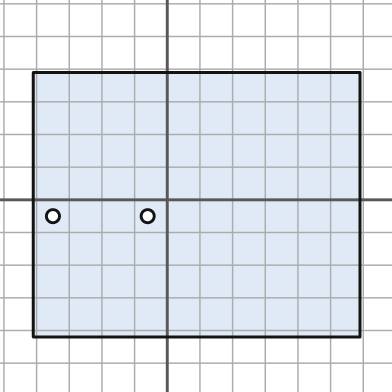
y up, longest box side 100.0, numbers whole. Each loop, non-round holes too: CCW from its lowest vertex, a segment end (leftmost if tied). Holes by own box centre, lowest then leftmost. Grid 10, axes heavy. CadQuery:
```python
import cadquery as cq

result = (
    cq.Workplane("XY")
    .moveTo(-41.0, -42.0)
    .lineTo(59.0, -42.0)
    .lineTo(59.0, 39.0)
    .lineTo(-41.0, 39.0)
    .close()
    .moveTo(-35.0, -5.0)
    .circle(2.0)
    .moveTo(-6.0, -5.0)
    .circle(2.0)
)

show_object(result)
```